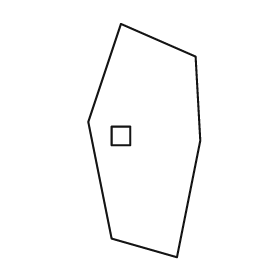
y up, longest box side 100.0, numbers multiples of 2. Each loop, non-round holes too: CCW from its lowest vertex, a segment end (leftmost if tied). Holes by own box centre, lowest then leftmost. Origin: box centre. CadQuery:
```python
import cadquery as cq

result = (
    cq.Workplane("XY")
    .moveTo(14.0, -50.0)
    .lineTo(24.0, 0.0)
    .lineTo(22.0, 36.0)
    .lineTo(-10.0, 50.0)
    .lineTo(-24.0, 8.0)
    .lineTo(-14.0, -42.0)
    .close()
    .moveTo(-14.0, -2.0)
    .lineTo(-6.0, -2.0)
    .lineTo(-6.0, 6.0)
    .lineTo(-14.0, 6.0)
    .close()
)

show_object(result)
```